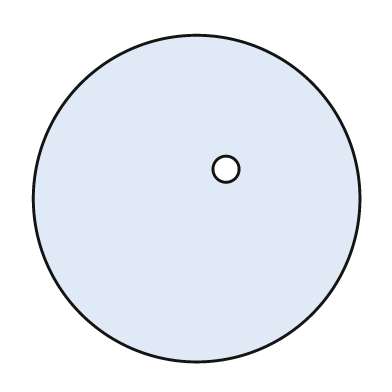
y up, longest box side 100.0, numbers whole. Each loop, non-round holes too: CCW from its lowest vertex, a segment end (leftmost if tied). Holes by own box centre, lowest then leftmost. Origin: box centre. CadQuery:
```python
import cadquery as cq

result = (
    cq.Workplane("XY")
    .moveTo(0.0, 0.0)
    .circle(50.0)
    .moveTo(9.0, 9.0)
    .circle(4.0)
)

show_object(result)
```